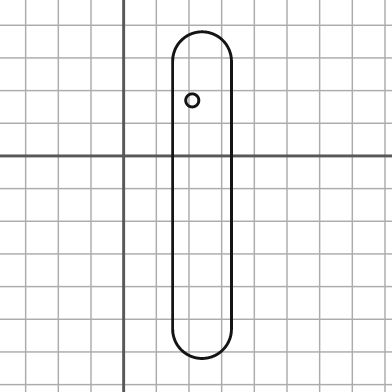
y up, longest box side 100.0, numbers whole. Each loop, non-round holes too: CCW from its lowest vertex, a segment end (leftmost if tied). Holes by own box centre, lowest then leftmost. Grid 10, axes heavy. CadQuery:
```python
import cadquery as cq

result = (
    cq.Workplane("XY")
    .moveTo(15.0, -53.0)
    .threePointArc((24.0, -62.0), (33.0, -53.0))
    .lineTo(33.0, 29.0)
    .threePointArc((24.0, 38.0), (15.0, 29.0))
    .close()
    .moveTo(21.0, 17.0)
    .circle(2.0)
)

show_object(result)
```